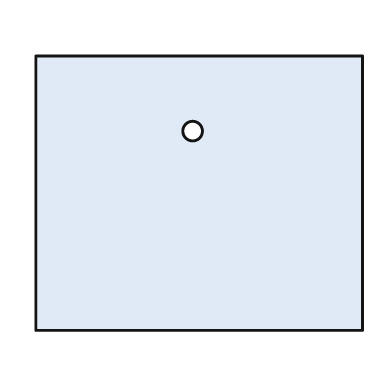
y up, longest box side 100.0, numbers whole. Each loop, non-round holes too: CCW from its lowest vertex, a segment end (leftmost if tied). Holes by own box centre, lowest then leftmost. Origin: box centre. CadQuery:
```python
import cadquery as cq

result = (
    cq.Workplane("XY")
    .moveTo(-50.0, -42.0)
    .lineTo(50.0, -42.0)
    .lineTo(50.0, 42.0)
    .lineTo(-50.0, 42.0)
    .close()
    .moveTo(-2.0, 19.0)
    .circle(3.0)
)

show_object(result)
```